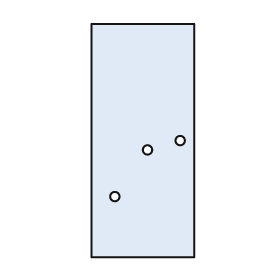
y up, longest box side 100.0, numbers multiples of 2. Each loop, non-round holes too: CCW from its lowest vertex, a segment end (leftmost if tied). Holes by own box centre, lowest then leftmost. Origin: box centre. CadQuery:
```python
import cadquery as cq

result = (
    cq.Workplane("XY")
    .moveTo(-22.0, -50.0)
    .lineTo(22.0, -50.0)
    .lineTo(22.0, 50.0)
    .lineTo(-22.0, 50.0)
    .close()
    .moveTo(-12.0, -24.0)
    .circle(2.0)
    .moveTo(2.0, -4.0)
    .circle(2.0)
    .moveTo(16.0, 0.0)
    .circle(2.0)
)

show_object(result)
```